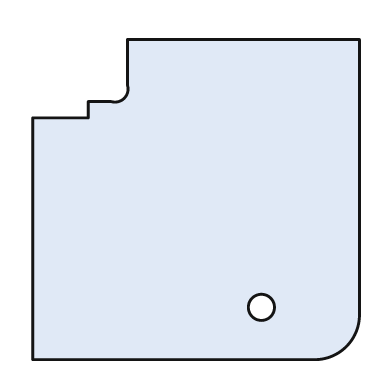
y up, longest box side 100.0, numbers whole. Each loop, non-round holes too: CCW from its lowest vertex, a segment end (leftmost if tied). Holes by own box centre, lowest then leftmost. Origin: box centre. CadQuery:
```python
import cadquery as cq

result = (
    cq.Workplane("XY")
    .moveTo(-50.0, -49.0)
    .lineTo(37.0, -49.0)
    .threePointArc((46.0, -45.0), (50.0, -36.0))
    .lineTo(50.0, 49.0)
    .lineTo(-21.0, 49.0)
    .lineTo(-21.0, 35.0)
    .threePointArc((-22.0, 31.0), (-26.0, 30.0))
    .lineTo(-33.0, 30.0)
    .lineTo(-33.0, 25.0)
    .lineTo(-50.0, 25.0)
    .close()
    .moveTo(20.0, -33.0)
    .circle(4.0)
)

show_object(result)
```